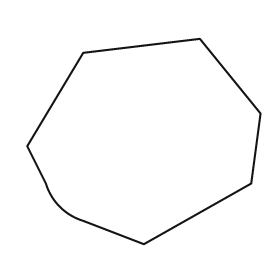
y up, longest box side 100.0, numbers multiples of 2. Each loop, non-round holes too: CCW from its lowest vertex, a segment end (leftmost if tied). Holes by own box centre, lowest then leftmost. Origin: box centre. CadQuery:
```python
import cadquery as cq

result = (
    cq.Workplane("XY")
    .moveTo(0.0, -44.0)
    .lineTo(46.0, -18.0)
    .lineTo(50.0, 12.0)
    .lineTo(24.0, 44.0)
    .lineTo(-26.0, 38.0)
    .lineTo(-50.0, -2.0)
    .lineTo(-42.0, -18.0)
    .threePointArc((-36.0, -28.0), (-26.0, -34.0))
    .close()
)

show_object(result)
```